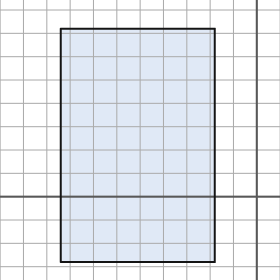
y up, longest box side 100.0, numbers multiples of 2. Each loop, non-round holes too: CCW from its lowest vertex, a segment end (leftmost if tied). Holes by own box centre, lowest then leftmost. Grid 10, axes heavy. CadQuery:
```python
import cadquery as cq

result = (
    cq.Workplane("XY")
    .moveTo(-84.0, -28.0)
    .lineTo(-18.0, -28.0)
    .lineTo(-18.0, 72.0)
    .lineTo(-84.0, 72.0)
    .close()
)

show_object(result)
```